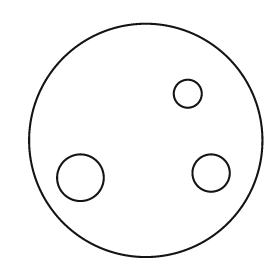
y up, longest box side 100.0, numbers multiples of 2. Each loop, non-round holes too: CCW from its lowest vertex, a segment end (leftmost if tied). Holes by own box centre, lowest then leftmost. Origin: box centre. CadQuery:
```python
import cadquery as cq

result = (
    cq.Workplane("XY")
    .moveTo(0.0, 0.0)
    .circle(50.0)
    .moveTo(-28.0, -16.0)
    .circle(10.0)
    .moveTo(28.0, -14.0)
    .circle(8.0)
    .moveTo(18.0, 20.0)
    .circle(6.0)
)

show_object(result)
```